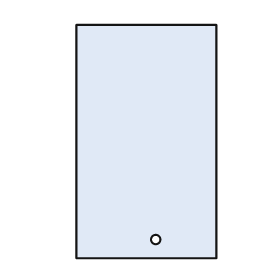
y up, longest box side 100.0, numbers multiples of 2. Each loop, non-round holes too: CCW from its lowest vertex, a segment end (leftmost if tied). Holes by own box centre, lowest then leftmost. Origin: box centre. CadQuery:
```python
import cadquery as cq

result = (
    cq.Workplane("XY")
    .moveTo(-30.0, -50.0)
    .lineTo(30.0, -50.0)
    .lineTo(30.0, 50.0)
    .lineTo(-30.0, 50.0)
    .close()
    .moveTo(4.0, -42.0)
    .circle(2.0)
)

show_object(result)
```